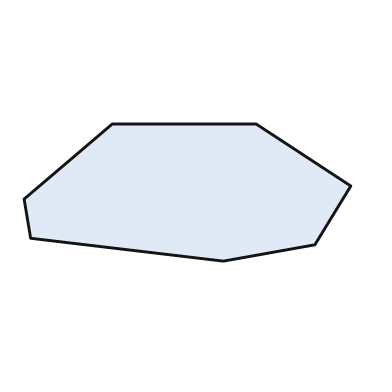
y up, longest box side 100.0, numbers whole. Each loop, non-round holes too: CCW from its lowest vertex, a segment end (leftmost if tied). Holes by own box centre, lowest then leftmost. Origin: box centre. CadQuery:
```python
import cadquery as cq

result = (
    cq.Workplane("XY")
    .moveTo(11.0, -21.0)
    .lineTo(39.0, -16.0)
    .lineTo(50.0, 2.0)
    .lineTo(21.0, 21.0)
    .lineTo(-23.0, 21.0)
    .lineTo(-50.0, -2.0)
    .lineTo(-48.0, -14.0)
    .close()
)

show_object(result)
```